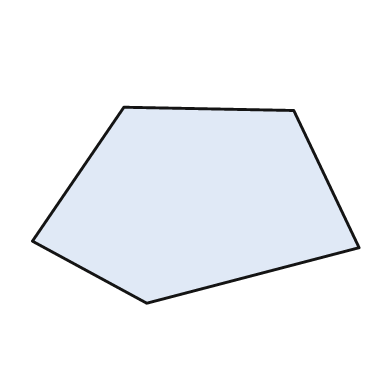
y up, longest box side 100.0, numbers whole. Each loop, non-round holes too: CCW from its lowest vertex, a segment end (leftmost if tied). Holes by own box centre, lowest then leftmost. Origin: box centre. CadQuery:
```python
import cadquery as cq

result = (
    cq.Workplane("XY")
    .moveTo(-15.0, -30.0)
    .lineTo(50.0, -13.0)
    .lineTo(30.0, 29.0)
    .lineTo(-22.0, 30.0)
    .lineTo(-50.0, -11.0)
    .close()
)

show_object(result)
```